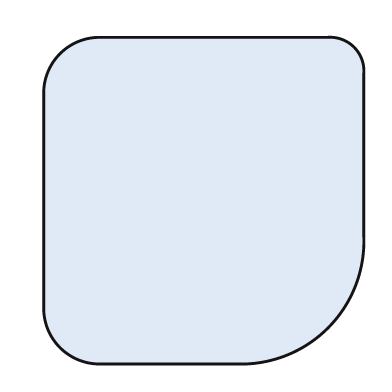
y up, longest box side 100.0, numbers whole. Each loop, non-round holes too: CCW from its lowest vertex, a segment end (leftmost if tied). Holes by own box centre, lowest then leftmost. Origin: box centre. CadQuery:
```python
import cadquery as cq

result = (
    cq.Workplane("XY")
    .moveTo(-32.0, -50.0)
    .lineTo(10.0, -50.0)
    .threePointArc((38.0, -39.0), (49.0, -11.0))
    .lineTo(49.0, 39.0)
    .threePointArc((46.0, 47.0), (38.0, 50.0))
    .lineTo(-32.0, 50.0)
    .threePointArc((-44.0, 45.0), (-49.0, 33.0))
    .lineTo(-49.0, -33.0)
    .threePointArc((-44.0, -45.0), (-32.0, -50.0))
    .close()
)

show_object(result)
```